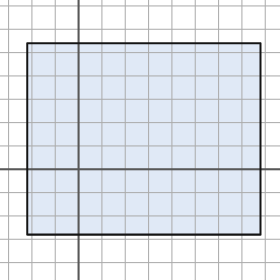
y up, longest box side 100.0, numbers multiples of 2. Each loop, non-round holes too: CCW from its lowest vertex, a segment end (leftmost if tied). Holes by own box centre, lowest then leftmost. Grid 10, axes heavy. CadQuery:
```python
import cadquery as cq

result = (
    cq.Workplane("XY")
    .moveTo(-22.0, -28.0)
    .lineTo(78.0, -28.0)
    .lineTo(78.0, 54.0)
    .lineTo(-22.0, 54.0)
    .close()
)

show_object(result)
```